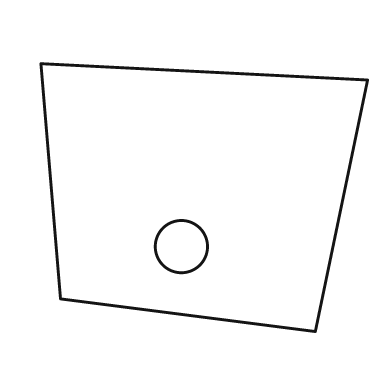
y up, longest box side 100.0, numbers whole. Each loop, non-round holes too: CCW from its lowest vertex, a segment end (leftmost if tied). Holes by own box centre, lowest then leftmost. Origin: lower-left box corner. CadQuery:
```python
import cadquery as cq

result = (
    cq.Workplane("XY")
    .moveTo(84.0, 0.0)
    .lineTo(100.0, 77.0)
    .lineTo(0.0, 82.0)
    .lineTo(6.0, 10.0)
    .close()
    .moveTo(43.0, 26.0)
    .circle(8.0)
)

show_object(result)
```